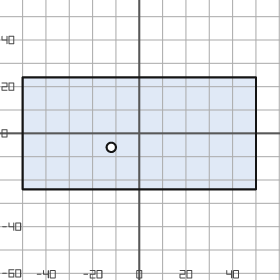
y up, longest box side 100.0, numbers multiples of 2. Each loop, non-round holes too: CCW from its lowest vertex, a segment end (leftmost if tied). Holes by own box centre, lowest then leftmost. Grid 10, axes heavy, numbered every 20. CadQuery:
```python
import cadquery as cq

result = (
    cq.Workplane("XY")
    .moveTo(-50.0, -24.0)
    .lineTo(50.0, -24.0)
    .lineTo(50.0, 24.0)
    .lineTo(-50.0, 24.0)
    .close()
    .moveTo(-12.0, -6.0)
    .circle(2.0)
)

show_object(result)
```